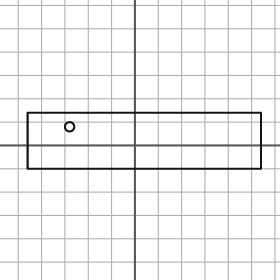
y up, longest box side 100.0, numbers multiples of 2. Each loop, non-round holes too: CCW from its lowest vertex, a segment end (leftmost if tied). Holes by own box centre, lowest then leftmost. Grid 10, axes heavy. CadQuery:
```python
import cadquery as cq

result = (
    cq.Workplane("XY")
    .moveTo(-46.0, -10.0)
    .lineTo(54.0, -10.0)
    .lineTo(54.0, 14.0)
    .lineTo(-46.0, 14.0)
    .close()
    .moveTo(-28.0, 8.0)
    .circle(2.0)
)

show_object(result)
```